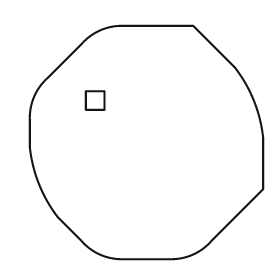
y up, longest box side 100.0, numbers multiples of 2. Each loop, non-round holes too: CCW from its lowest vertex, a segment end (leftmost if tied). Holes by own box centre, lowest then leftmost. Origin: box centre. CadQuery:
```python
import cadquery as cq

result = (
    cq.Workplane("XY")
    .moveTo(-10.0, -50.0)
    .lineTo(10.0, -50.0)
    .threePointArc((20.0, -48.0), (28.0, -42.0))
    .lineTo(50.0, -20.0)
    .lineTo(50.0, 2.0)
    .threePointArc((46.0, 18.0), (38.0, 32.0))
    .lineTo(20.0, 50.0)
    .lineTo(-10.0, 50.0)
    .threePointArc((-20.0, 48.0), (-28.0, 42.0))
    .lineTo(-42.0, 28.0)
    .threePointArc((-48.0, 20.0), (-50.0, 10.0))
    .lineTo(-50.0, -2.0)
    .threePointArc((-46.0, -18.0), (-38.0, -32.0))
    .lineTo(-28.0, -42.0)
    .threePointArc((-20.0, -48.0), (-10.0, -50.0))
    .close()
    .moveTo(-26.0, 14.0)
    .lineTo(-18.0, 14.0)
    .lineTo(-18.0, 22.0)
    .lineTo(-26.0, 22.0)
    .close()
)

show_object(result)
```